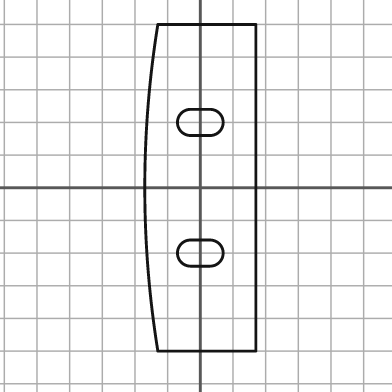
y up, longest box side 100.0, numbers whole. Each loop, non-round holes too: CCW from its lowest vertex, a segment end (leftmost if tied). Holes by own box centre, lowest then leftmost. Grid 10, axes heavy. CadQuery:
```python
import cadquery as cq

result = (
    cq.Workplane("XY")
    .moveTo(-13.0, -50.0)
    .lineTo(17.0, -50.0)
    .lineTo(17.0, 50.0)
    .lineTo(-13.0, 50.0)
    .threePointArc((-17.0, 0.0), (-13.0, -50.0))
    .close()
    .moveTo(-3.0, -24.0)
    .lineTo(3.0, -24.0)
    .threePointArc((7.0, -20.0), (3.0, -16.0))
    .lineTo(-3.0, -16.0)
    .threePointArc((-7.0, -20.0), (-3.0, -24.0))
    .close()
    .moveTo(-3.0, 16.0)
    .lineTo(3.0, 16.0)
    .threePointArc((7.0, 20.0), (3.0, 24.0))
    .lineTo(-3.0, 24.0)
    .threePointArc((-7.0, 20.0), (-3.0, 16.0))
    .close()
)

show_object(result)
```